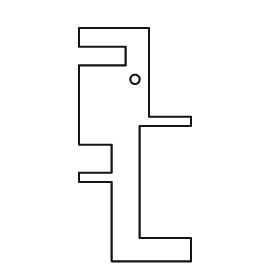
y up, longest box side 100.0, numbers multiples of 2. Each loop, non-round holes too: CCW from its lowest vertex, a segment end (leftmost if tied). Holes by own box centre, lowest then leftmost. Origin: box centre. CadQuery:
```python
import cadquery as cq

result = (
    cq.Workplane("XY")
    .moveTo(-10.0, -50.0)
    .lineTo(24.0, -50.0)
    .lineTo(24.0, -40.0)
    .lineTo(2.0, -40.0)
    .lineTo(2.0, 8.0)
    .lineTo(24.0, 8.0)
    .lineTo(24.0, 12.0)
    .lineTo(6.0, 12.0)
    .lineTo(6.0, 50.0)
    .lineTo(-24.0, 50.0)
    .lineTo(-24.0, 42.0)
    .lineTo(-4.0, 42.0)
    .lineTo(-4.0, 34.0)
    .lineTo(-24.0, 34.0)
    .lineTo(-24.0, 0.0)
    .lineTo(-10.0, 0.0)
    .lineTo(-10.0, -12.0)
    .lineTo(-24.0, -12.0)
    .lineTo(-24.0, -16.0)
    .lineTo(-10.0, -16.0)
    .close()
    .moveTo(0.0, 28.0)
    .circle(2.0)
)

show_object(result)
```